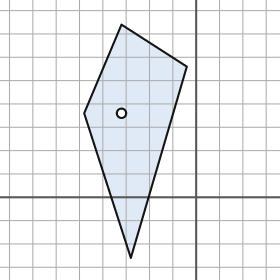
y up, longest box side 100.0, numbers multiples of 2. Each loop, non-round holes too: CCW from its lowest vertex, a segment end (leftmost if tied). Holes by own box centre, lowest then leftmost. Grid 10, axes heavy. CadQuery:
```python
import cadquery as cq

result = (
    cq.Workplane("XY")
    .moveTo(-28.0, -26.0)
    .lineTo(-4.0, 56.0)
    .lineTo(-32.0, 74.0)
    .lineTo(-48.0, 36.0)
    .close()
    .moveTo(-32.0, 36.0)
    .circle(2.0)
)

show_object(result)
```